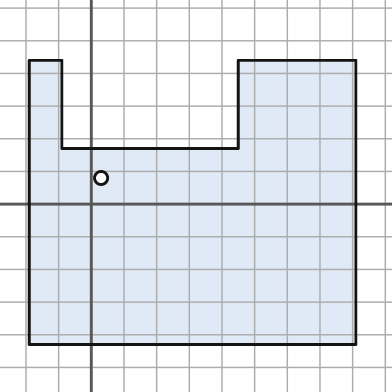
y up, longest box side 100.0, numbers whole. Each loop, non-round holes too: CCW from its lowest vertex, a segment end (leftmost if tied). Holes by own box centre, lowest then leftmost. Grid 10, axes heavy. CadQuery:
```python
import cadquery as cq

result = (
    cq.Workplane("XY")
    .moveTo(-19.0, -43.0)
    .lineTo(81.0, -43.0)
    .lineTo(81.0, 44.0)
    .lineTo(45.0, 44.0)
    .lineTo(45.0, 17.0)
    .lineTo(-9.0, 17.0)
    .lineTo(-9.0, 44.0)
    .lineTo(-19.0, 44.0)
    .close()
    .moveTo(3.0, 8.0)
    .circle(2.0)
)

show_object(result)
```